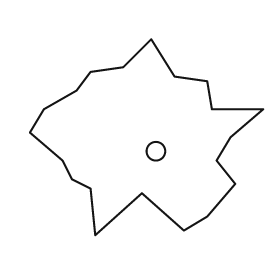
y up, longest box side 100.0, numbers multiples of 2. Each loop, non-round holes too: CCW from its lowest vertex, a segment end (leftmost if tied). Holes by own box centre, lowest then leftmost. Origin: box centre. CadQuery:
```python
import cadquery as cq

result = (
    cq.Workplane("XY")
    .moveTo(-22.0, -42.0)
    .lineTo(-2.0, -24.0)
    .lineTo(16.0, -40.0)
    .lineTo(26.0, -34.0)
    .lineTo(38.0, -20.0)
    .lineTo(30.0, -10.0)
    .lineTo(36.0, 0.0)
    .lineTo(50.0, 12.0)
    .lineTo(28.0, 12.0)
    .lineTo(26.0, 24.0)
    .lineTo(12.0, 26.0)
    .lineTo(2.0, 42.0)
    .lineTo(-10.0, 30.0)
    .lineTo(-24.0, 28.0)
    .lineTo(-30.0, 20.0)
    .lineTo(-44.0, 12.0)
    .lineTo(-50.0, 2.0)
    .lineTo(-36.0, -10.0)
    .lineTo(-32.0, -18.0)
    .lineTo(-24.0, -22.0)
    .close()
    .moveTo(4.0, -6.0)
    .circle(4.0)
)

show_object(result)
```